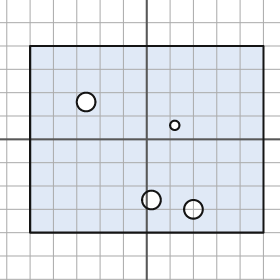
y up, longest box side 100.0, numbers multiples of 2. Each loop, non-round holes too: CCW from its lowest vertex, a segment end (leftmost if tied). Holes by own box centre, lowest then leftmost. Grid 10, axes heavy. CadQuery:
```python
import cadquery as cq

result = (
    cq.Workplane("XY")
    .moveTo(-50.0, -40.0)
    .lineTo(50.0, -40.0)
    .lineTo(50.0, 40.0)
    .lineTo(-50.0, 40.0)
    .close()
    .moveTo(20.0, -30.0)
    .circle(4.0)
    .moveTo(2.0, -26.0)
    .circle(4.0)
    .moveTo(12.0, 6.0)
    .circle(2.0)
    .moveTo(-26.0, 16.0)
    .circle(4.0)
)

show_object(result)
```